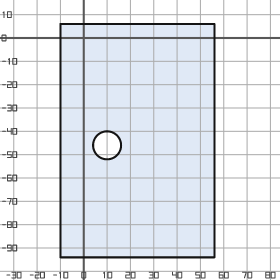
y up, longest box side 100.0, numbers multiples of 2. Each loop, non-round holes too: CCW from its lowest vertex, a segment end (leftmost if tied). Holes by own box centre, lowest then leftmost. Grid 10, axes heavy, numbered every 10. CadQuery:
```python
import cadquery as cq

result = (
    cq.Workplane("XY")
    .moveTo(-10.0, -94.0)
    .lineTo(56.0, -94.0)
    .lineTo(56.0, 6.0)
    .lineTo(-10.0, 6.0)
    .close()
    .moveTo(10.0, -46.0)
    .circle(6.0)
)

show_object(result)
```